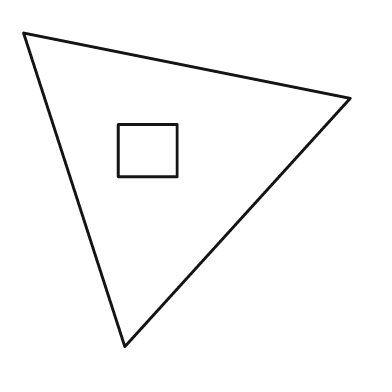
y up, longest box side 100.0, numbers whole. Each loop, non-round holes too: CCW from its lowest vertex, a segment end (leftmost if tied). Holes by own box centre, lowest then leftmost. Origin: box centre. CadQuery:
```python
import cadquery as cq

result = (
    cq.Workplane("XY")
    .moveTo(-19.0, -48.0)
    .lineTo(50.0, 28.0)
    .lineTo(-50.0, 48.0)
    .close()
    .moveTo(-21.0, 4.0)
    .lineTo(-3.0, 4.0)
    .lineTo(-3.0, 20.0)
    .lineTo(-21.0, 20.0)
    .close()
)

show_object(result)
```